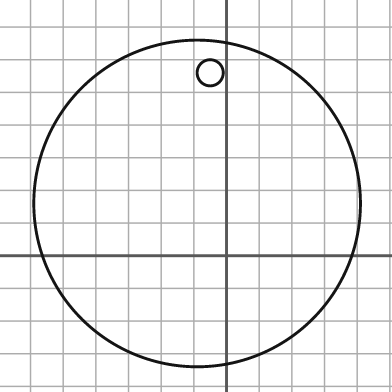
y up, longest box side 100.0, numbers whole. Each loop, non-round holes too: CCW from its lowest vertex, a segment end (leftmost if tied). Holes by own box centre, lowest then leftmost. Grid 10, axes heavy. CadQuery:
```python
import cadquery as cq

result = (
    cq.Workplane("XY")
    .moveTo(-9.0, 16.0)
    .circle(50.0)
    .moveTo(-5.0, 56.0)
    .circle(4.0)
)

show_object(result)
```